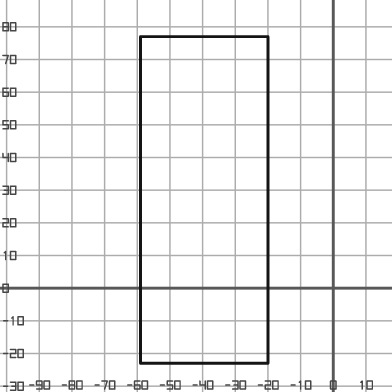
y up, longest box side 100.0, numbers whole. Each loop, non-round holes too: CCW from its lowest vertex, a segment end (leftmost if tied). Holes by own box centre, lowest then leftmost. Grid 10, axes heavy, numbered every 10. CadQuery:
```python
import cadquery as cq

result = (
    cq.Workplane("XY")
    .moveTo(-59.0, -23.0)
    .lineTo(-20.0, -23.0)
    .lineTo(-20.0, 77.0)
    .lineTo(-59.0, 77.0)
    .close()
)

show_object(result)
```